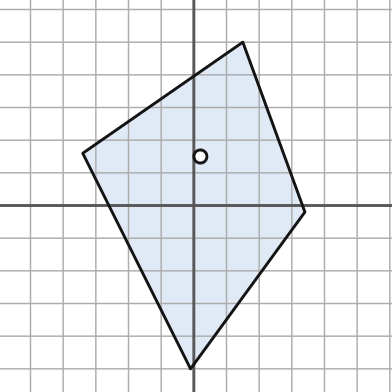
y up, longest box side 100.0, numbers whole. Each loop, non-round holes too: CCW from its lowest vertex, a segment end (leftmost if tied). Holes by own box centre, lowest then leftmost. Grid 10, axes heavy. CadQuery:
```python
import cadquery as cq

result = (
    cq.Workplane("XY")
    .moveTo(-1.0, -50.0)
    .lineTo(34.0, -2.0)
    .lineTo(15.0, 50.0)
    .lineTo(-34.0, 16.0)
    .close()
    .moveTo(2.0, 15.0)
    .circle(2.0)
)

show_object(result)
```